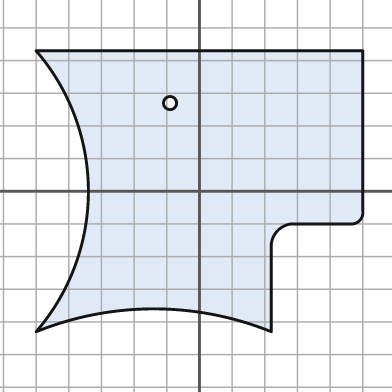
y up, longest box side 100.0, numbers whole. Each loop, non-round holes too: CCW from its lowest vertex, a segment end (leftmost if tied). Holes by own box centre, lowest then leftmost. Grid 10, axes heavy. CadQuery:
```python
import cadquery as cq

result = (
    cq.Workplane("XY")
    .moveTo(-50.0, -43.0)
    .threePointArc((-14.0, -36.0), (22.0, -43.0))
    .lineTo(22.0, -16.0)
    .threePointArc((24.0, -12.0), (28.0, -10.0))
    .lineTo(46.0, -10.0)
    .threePointArc((49.0, -9.0), (50.0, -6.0))
    .lineTo(50.0, 43.0)
    .lineTo(-50.0, 43.0)
    .threePointArc((-34.0, 0.0), (-50.0, -43.0))
    .close()
    .moveTo(-9.0, 27.0)
    .circle(2.0)
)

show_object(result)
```